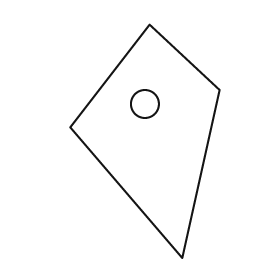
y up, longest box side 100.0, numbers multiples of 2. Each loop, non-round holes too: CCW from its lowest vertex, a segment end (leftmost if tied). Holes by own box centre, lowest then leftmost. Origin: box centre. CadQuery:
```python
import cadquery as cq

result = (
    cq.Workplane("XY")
    .moveTo(16.0, -50.0)
    .lineTo(32.0, 22.0)
    .lineTo(2.0, 50.0)
    .lineTo(-32.0, 6.0)
    .close()
    .moveTo(0.0, 16.0)
    .circle(6.0)
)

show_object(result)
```